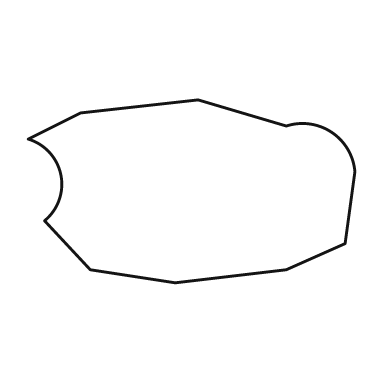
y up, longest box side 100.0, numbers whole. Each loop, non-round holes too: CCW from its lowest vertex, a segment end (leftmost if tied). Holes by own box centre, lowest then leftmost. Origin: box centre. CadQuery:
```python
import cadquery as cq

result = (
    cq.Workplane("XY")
    .moveTo(-5.0, -28.0)
    .lineTo(29.0, -24.0)
    .lineTo(47.0, -16.0)
    .lineTo(50.0, 6.0)
    .threePointArc((43.0, 18.0), (29.0, 20.0))
    .lineTo(2.0, 28.0)
    .lineTo(-34.0, 24.0)
    .lineTo(-50.0, 16.0)
    .threePointArc((-40.0, 5.0), (-45.0, -9.0))
    .lineTo(-31.0, -24.0)
    .close()
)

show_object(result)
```